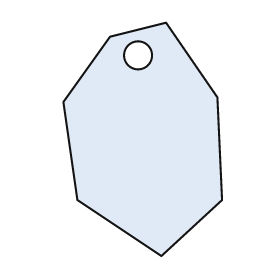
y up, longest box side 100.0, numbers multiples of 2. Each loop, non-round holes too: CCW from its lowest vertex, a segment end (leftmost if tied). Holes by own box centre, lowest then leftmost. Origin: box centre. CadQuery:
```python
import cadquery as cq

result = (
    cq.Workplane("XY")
    .moveTo(8.0, -50.0)
    .lineTo(34.0, -26.0)
    .lineTo(32.0, 18.0)
    .lineTo(10.0, 50.0)
    .lineTo(-14.0, 44.0)
    .lineTo(-34.0, 16.0)
    .lineTo(-28.0, -26.0)
    .close()
    .moveTo(-2.0, 36.0)
    .circle(6.0)
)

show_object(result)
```